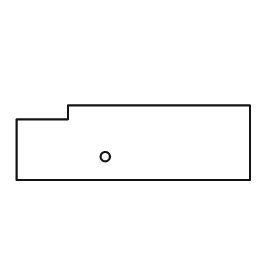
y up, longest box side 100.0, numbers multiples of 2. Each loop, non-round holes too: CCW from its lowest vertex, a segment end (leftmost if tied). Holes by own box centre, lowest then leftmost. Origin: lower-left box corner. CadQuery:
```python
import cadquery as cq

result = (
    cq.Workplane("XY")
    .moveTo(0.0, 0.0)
    .lineTo(100.0, 0.0)
    .lineTo(100.0, 32.0)
    .lineTo(22.0, 32.0)
    .lineTo(22.0, 26.0)
    .lineTo(0.0, 26.0)
    .close()
    .moveTo(38.0, 10.0)
    .circle(2.0)
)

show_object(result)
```